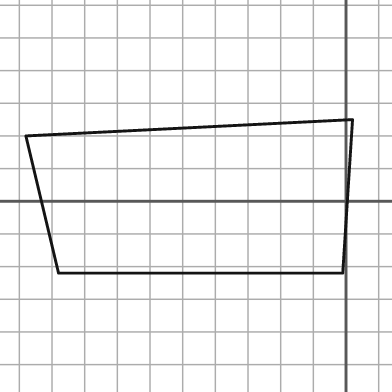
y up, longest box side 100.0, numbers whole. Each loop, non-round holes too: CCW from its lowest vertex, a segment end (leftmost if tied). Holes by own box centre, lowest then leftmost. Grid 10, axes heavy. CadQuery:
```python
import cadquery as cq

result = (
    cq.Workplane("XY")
    .moveTo(-88.0, -22.0)
    .lineTo(-1.0, -22.0)
    .lineTo(2.0, 25.0)
    .lineTo(-98.0, 20.0)
    .close()
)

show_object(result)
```